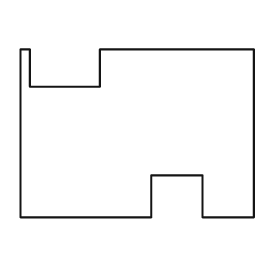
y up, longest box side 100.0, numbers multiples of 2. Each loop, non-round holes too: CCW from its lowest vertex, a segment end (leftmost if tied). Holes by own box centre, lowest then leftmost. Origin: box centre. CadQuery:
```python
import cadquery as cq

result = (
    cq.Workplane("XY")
    .moveTo(-50.0, -36.0)
    .lineTo(6.0, -36.0)
    .lineTo(6.0, -18.0)
    .lineTo(28.0, -18.0)
    .lineTo(28.0, -36.0)
    .lineTo(50.0, -36.0)
    .lineTo(50.0, 36.0)
    .lineTo(-16.0, 36.0)
    .lineTo(-16.0, 20.0)
    .lineTo(-46.0, 20.0)
    .lineTo(-46.0, 36.0)
    .lineTo(-50.0, 36.0)
    .close()
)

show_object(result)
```